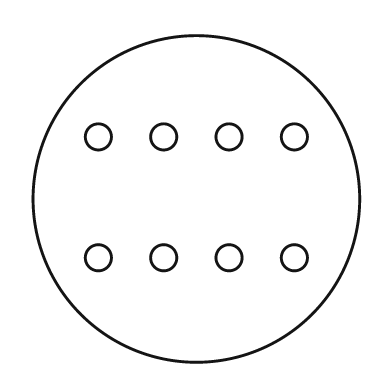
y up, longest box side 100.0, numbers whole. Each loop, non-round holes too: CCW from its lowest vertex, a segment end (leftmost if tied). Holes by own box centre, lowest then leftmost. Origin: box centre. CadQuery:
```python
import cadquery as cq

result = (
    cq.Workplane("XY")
    .moveTo(0.0, 0.0)
    .circle(50.0)
    .moveTo(-30.0, -18.0)
    .circle(4.0)
    .moveTo(-10.0, -18.0)
    .circle(4.0)
    .moveTo(10.0, -18.0)
    .circle(4.0)
    .moveTo(30.0, -18.0)
    .circle(4.0)
    .moveTo(-30.0, 19.0)
    .circle(4.0)
    .moveTo(-10.0, 19.0)
    .circle(4.0)
    .moveTo(10.0, 19.0)
    .circle(4.0)
    .moveTo(30.0, 19.0)
    .circle(4.0)
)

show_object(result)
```